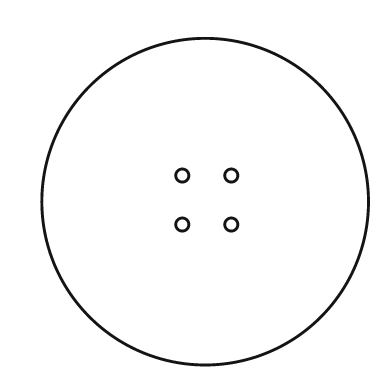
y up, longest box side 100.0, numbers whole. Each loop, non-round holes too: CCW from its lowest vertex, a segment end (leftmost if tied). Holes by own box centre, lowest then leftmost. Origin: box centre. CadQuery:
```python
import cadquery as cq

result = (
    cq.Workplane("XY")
    .moveTo(0.0, 0.0)
    .circle(50.0)
    .moveTo(-7.0, -7.0)
    .circle(2.0)
    .moveTo(8.0, -7.0)
    .circle(2.0)
    .moveTo(-7.0, 8.0)
    .circle(2.0)
    .moveTo(8.0, 8.0)
    .circle(2.0)
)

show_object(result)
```